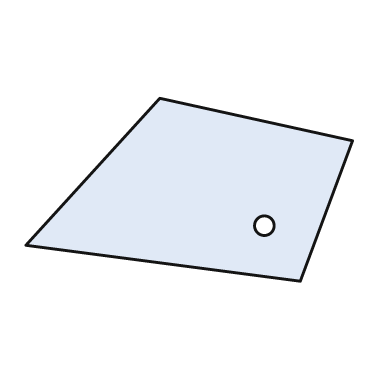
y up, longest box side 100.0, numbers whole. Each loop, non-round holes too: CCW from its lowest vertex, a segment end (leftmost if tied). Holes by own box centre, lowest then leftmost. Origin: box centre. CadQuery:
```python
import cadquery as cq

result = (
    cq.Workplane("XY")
    .moveTo(34.0, -28.0)
    .lineTo(50.0, 15.0)
    .lineTo(-9.0, 28.0)
    .lineTo(-50.0, -17.0)
    .close()
    .moveTo(23.0, -11.0)
    .circle(3.0)
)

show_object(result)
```